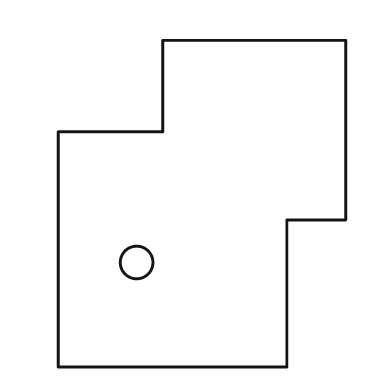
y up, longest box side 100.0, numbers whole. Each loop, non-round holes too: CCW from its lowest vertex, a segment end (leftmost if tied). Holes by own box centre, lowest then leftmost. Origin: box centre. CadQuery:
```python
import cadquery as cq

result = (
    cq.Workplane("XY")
    .moveTo(-44.0, -50.0)
    .lineTo(26.0, -50.0)
    .lineTo(26.0, -5.0)
    .lineTo(44.0, -5.0)
    .lineTo(44.0, 50.0)
    .lineTo(-12.0, 50.0)
    .lineTo(-12.0, 22.0)
    .lineTo(-44.0, 22.0)
    .close()
    .moveTo(-20.0, -18.0)
    .circle(5.0)
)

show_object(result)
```